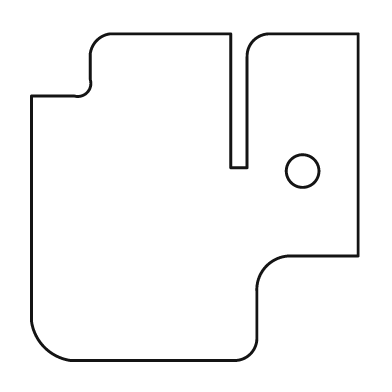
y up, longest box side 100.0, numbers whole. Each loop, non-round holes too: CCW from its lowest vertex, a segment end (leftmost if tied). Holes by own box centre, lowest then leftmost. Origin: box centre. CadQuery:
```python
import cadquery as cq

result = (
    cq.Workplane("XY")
    .moveTo(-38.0, -50.0)
    .lineTo(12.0, -50.0)
    .threePointArc((17.0, -48.0), (19.0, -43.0))
    .lineTo(19.0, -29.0)
    .threePointArc((22.0, -21.0), (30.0, -18.0))
    .lineTo(50.0, -18.0)
    .lineTo(50.0, 50.0)
    .lineTo(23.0, 50.0)
    .threePointArc((18.0, 48.0), (16.0, 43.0))
    .lineTo(16.0, 9.0)
    .lineTo(11.0, 9.0)
    .lineTo(11.0, 50.0)
    .lineTo(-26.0, 50.0)
    .threePointArc((-30.0, 48.0), (-32.0, 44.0))
    .lineTo(-32.0, 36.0)
    .threePointArc((-33.0, 32.0), (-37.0, 31.0))
    .lineTo(-50.0, 31.0)
    .lineTo(-50.0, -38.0)
    .threePointArc((-46.0, -46.0), (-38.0, -50.0))
    .close()
    .moveTo(33.0, 8.0)
    .circle(5.0)
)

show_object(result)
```